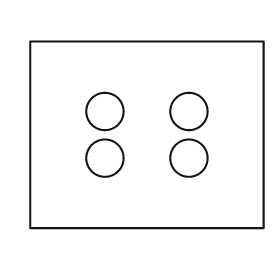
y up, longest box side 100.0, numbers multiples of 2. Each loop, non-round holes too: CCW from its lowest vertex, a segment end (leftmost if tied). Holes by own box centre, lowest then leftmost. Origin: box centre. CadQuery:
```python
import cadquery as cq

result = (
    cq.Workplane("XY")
    .moveTo(-50.0, -40.0)
    .lineTo(50.0, -40.0)
    .lineTo(50.0, 40.0)
    .lineTo(-50.0, 40.0)
    .close()
    .moveTo(-18.0, -10.0)
    .circle(8.0)
    .moveTo(18.0, -10.0)
    .circle(8.0)
    .moveTo(-18.0, 10.0)
    .circle(8.0)
    .moveTo(18.0, 10.0)
    .circle(8.0)
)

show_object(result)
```